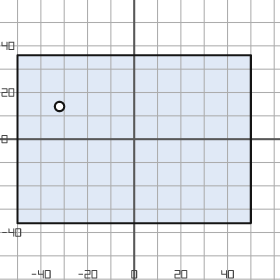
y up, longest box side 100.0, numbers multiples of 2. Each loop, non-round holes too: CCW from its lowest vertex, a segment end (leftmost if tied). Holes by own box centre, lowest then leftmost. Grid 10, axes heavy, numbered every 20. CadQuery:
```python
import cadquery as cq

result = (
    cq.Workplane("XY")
    .moveTo(-50.0, -36.0)
    .lineTo(50.0, -36.0)
    .lineTo(50.0, 36.0)
    .lineTo(-50.0, 36.0)
    .close()
    .moveTo(-32.0, 14.0)
    .circle(2.0)
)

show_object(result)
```